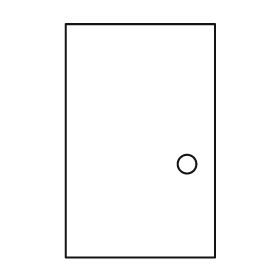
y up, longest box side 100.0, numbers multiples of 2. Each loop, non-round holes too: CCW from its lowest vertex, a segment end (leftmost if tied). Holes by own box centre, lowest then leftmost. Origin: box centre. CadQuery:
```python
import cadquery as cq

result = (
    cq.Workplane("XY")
    .moveTo(-32.0, -50.0)
    .lineTo(32.0, -50.0)
    .lineTo(32.0, 50.0)
    .lineTo(-32.0, 50.0)
    .close()
    .moveTo(20.0, -10.0)
    .circle(4.0)
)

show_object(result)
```